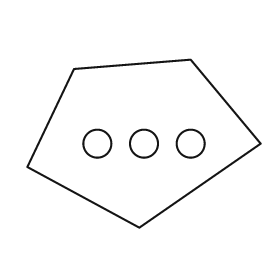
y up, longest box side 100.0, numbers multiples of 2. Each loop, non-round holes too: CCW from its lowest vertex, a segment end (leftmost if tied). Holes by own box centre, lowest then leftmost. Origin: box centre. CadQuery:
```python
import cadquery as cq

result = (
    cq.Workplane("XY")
    .moveTo(-2.0, -36.0)
    .lineTo(50.0, 0.0)
    .lineTo(20.0, 36.0)
    .lineTo(-30.0, 32.0)
    .lineTo(-50.0, -10.0)
    .close()
    .moveTo(-20.0, 0.0)
    .circle(6.0)
    .moveTo(0.0, 0.0)
    .circle(6.0)
    .moveTo(20.0, 0.0)
    .circle(6.0)
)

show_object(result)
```